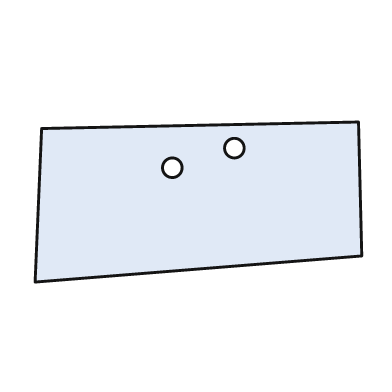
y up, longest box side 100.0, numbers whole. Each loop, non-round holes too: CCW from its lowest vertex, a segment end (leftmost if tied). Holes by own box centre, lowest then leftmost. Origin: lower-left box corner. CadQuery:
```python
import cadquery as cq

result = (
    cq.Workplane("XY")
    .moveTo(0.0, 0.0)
    .lineTo(100.0, 8.0)
    .lineTo(99.0, 49.0)
    .lineTo(2.0, 47.0)
    .close()
    .moveTo(42.0, 35.0)
    .circle(3.0)
    .moveTo(61.0, 41.0)
    .circle(3.0)
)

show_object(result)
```